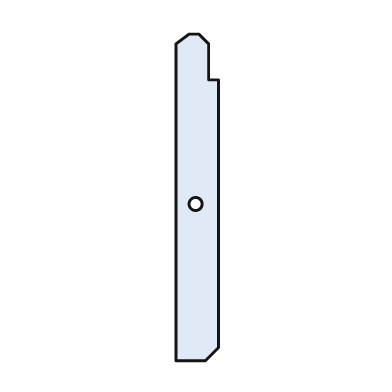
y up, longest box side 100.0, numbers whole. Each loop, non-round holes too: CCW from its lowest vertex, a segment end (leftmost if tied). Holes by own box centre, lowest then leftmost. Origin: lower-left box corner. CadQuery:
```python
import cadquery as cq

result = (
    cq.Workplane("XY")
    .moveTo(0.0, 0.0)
    .lineTo(9.0, 0.0)
    .lineTo(13.0, 4.0)
    .lineTo(13.0, 86.0)
    .lineTo(10.0, 86.0)
    .lineTo(10.0, 97.0)
    .lineTo(7.0, 100.0)
    .lineTo(4.0, 100.0)
    .lineTo(0.0, 97.0)
    .close()
    .moveTo(6.0, 48.0)
    .circle(2.0)
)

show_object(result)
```